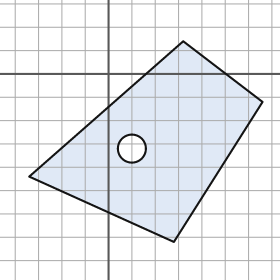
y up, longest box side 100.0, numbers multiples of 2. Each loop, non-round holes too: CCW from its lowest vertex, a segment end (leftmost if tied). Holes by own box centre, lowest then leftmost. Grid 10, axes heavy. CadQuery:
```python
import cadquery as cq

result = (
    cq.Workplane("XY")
    .moveTo(28.0, -72.0)
    .lineTo(66.0, -12.0)
    .lineTo(32.0, 14.0)
    .lineTo(-34.0, -44.0)
    .close()
    .moveTo(10.0, -32.0)
    .circle(6.0)
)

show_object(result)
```